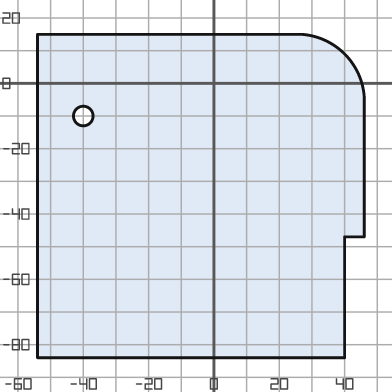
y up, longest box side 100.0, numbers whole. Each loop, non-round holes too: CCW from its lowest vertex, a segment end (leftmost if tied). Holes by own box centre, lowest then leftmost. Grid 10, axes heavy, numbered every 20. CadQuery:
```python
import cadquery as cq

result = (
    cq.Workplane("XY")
    .moveTo(-54.0, -84.0)
    .lineTo(40.0, -84.0)
    .lineTo(40.0, -47.0)
    .lineTo(46.0, -47.0)
    .lineTo(46.0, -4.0)
    .threePointArc((40.0, 9.0), (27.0, 15.0))
    .lineTo(-54.0, 15.0)
    .close()
    .moveTo(-40.0, -10.0)
    .circle(3.0)
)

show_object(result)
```